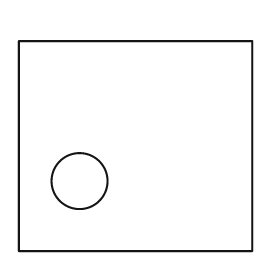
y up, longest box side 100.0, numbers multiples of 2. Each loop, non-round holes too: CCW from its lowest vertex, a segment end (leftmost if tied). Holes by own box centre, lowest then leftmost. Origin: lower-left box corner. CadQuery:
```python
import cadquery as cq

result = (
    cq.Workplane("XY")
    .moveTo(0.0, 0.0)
    .lineTo(100.0, 0.0)
    .lineTo(100.0, 90.0)
    .lineTo(0.0, 90.0)
    .close()
    .moveTo(26.0, 30.0)
    .circle(12.0)
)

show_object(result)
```